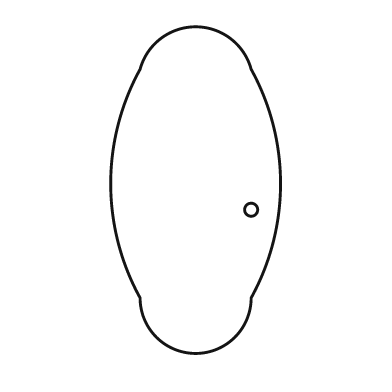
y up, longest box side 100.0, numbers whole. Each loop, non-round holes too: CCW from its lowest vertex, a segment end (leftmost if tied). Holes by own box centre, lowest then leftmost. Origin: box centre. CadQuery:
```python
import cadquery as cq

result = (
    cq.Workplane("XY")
    .moveTo(-17.0, -33.0)
    .threePointArc((0.0, -50.0), (17.0, -33.0))
    .threePointArc((26.0, 2.0), (17.0, 37.0))
    .threePointArc((0.0, 50.0), (-17.0, 37.0))
    .threePointArc((-26.0, 2.0), (-17.0, -33.0))
    .close()
    .moveTo(17.0, -6.0)
    .circle(2.0)
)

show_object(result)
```